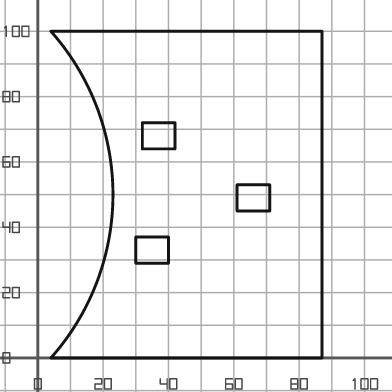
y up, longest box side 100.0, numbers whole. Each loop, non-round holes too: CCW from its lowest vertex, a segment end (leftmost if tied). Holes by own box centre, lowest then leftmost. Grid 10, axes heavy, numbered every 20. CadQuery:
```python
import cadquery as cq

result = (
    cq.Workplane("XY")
    .moveTo(4.0, 0.0)
    .lineTo(87.0, 0.0)
    .lineTo(87.0, 100.0)
    .lineTo(4.0, 100.0)
    .threePointArc((23.0, 50.0), (4.0, 0.0))
    .close()
    .moveTo(30.0, 29.0)
    .lineTo(40.0, 29.0)
    .lineTo(40.0, 37.0)
    .lineTo(30.0, 37.0)
    .close()
    .moveTo(61.0, 45.0)
    .lineTo(71.0, 45.0)
    .lineTo(71.0, 53.0)
    .lineTo(61.0, 53.0)
    .close()
    .moveTo(32.0, 64.0)
    .lineTo(42.0, 64.0)
    .lineTo(42.0, 72.0)
    .lineTo(32.0, 72.0)
    .close()
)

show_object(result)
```